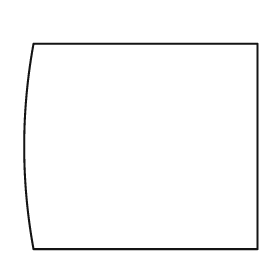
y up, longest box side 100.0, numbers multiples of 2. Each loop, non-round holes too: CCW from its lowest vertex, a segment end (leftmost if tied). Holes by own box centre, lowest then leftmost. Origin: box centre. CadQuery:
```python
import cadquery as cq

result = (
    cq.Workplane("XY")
    .moveTo(-46.0, -44.0)
    .lineTo(50.0, -44.0)
    .lineTo(50.0, 44.0)
    .lineTo(-46.0, 44.0)
    .threePointArc((-50.0, 0.0), (-46.0, -44.0))
    .close()
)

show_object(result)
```